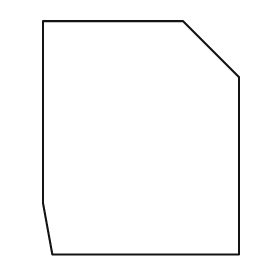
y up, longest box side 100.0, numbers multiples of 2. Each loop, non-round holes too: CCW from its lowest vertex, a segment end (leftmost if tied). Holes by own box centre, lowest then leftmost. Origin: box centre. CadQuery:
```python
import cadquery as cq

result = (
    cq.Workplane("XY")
    .moveTo(-38.0, -50.0)
    .lineTo(42.0, -50.0)
    .lineTo(42.0, 26.0)
    .lineTo(18.0, 50.0)
    .lineTo(-42.0, 50.0)
    .lineTo(-42.0, -28.0)
    .close()
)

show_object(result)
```